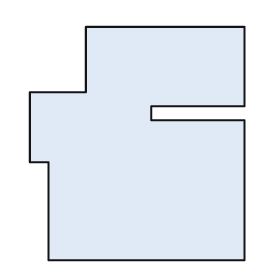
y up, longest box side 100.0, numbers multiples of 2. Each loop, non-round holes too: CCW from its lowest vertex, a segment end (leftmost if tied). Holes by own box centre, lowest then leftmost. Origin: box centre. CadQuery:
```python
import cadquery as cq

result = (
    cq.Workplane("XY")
    .moveTo(-38.0, -50.0)
    .lineTo(46.0, -50.0)
    .lineTo(46.0, 10.0)
    .lineTo(6.0, 10.0)
    .lineTo(6.0, 16.0)
    .lineTo(46.0, 16.0)
    .lineTo(46.0, 50.0)
    .lineTo(-22.0, 50.0)
    .lineTo(-22.0, 22.0)
    .lineTo(-46.0, 22.0)
    .lineTo(-46.0, -8.0)
    .lineTo(-38.0, -8.0)
    .close()
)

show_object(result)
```